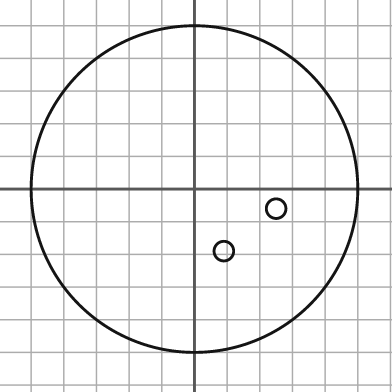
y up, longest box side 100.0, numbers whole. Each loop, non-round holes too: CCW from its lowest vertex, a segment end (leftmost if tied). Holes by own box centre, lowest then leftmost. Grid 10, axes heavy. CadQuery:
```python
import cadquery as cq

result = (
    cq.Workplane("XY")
    .moveTo(0.0, 0.0)
    .circle(50.0)
    .moveTo(9.0, -19.0)
    .circle(3.0)
    .moveTo(25.0, -6.0)
    .circle(3.0)
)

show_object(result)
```